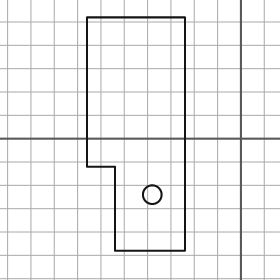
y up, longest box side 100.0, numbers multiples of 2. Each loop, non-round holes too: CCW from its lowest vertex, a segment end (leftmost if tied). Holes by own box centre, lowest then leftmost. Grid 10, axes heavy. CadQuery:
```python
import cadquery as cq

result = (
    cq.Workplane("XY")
    .moveTo(-54.0, -48.0)
    .lineTo(-24.0, -48.0)
    .lineTo(-24.0, 52.0)
    .lineTo(-66.0, 52.0)
    .lineTo(-66.0, -12.0)
    .lineTo(-54.0, -12.0)
    .close()
    .moveTo(-38.0, -24.0)
    .circle(4.0)
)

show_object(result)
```